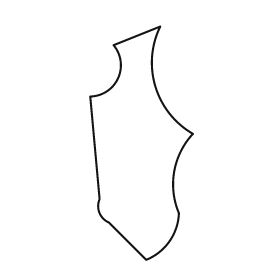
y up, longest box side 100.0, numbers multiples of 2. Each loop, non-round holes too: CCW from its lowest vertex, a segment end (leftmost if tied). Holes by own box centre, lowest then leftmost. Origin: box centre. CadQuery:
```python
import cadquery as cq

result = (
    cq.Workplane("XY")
    .moveTo(2.0, -50.0)
    .threePointArc((12.0, -42.0), (16.0, -30.0))
    .threePointArc((14.0, -12.0), (22.0, 4.0))
    .threePointArc((6.0, 24.0), (8.0, 50.0))
    .lineTo(-12.0, 42.0)
    .threePointArc((-10.0, 28.0), (-22.0, 20.0))
    .lineTo(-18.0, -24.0)
    .threePointArc((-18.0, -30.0), (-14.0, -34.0))
    .close()
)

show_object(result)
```